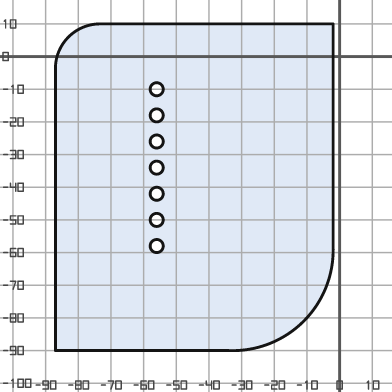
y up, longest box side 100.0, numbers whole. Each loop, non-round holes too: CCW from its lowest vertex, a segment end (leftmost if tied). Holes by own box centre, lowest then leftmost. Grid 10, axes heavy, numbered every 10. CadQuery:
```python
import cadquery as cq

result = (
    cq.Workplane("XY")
    .moveTo(-87.0, -90.0)
    .lineTo(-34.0, -90.0)
    .threePointArc((-11.0, -81.0), (-2.0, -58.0))
    .lineTo(-2.0, 10.0)
    .lineTo(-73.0, 10.0)
    .threePointArc((-83.0, 6.0), (-87.0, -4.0))
    .close()
    .moveTo(-56.0, -58.0)
    .circle(2.0)
    .moveTo(-56.0, -50.0)
    .circle(2.0)
    .moveTo(-56.0, -42.0)
    .circle(2.0)
    .moveTo(-56.0, -34.0)
    .circle(2.0)
    .moveTo(-56.0, -26.0)
    .circle(2.0)
    .moveTo(-56.0, -18.0)
    .circle(2.0)
    .moveTo(-56.0, -10.0)
    .circle(2.0)
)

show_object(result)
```